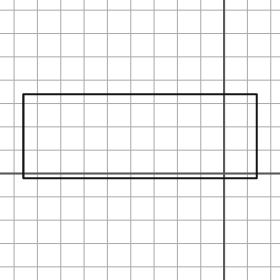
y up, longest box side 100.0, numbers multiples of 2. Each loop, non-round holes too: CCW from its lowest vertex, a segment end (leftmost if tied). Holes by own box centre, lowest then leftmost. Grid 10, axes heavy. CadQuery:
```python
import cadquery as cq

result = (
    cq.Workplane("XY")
    .moveTo(-86.0, -2.0)
    .lineTo(14.0, -2.0)
    .lineTo(14.0, 34.0)
    .lineTo(-86.0, 34.0)
    .close()
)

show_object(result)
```